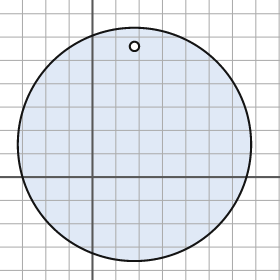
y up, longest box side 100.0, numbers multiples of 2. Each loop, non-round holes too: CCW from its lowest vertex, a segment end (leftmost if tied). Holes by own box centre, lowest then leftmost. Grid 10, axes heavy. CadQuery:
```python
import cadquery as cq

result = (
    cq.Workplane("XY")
    .moveTo(18.0, 14.0)
    .circle(50.0)
    .moveTo(18.0, 56.0)
    .circle(2.0)
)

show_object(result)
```